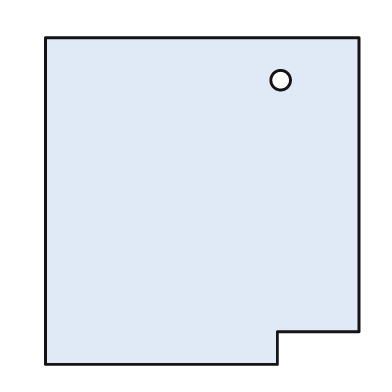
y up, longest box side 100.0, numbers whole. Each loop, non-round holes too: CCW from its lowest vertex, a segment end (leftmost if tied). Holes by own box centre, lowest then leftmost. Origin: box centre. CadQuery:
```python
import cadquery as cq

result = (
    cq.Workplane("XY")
    .moveTo(-48.0, -50.0)
    .lineTo(23.0, -50.0)
    .lineTo(23.0, -40.0)
    .lineTo(48.0, -40.0)
    .lineTo(48.0, 50.0)
    .lineTo(-48.0, 50.0)
    .close()
    .moveTo(24.0, 37.0)
    .circle(3.0)
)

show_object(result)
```